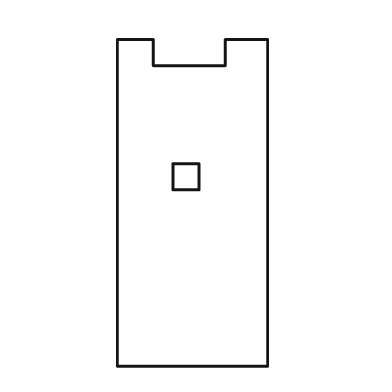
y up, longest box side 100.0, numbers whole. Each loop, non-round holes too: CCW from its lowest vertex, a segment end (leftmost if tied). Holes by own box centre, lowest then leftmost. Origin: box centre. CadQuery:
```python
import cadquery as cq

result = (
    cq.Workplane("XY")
    .moveTo(-23.0, -50.0)
    .lineTo(23.0, -50.0)
    .lineTo(23.0, 50.0)
    .lineTo(10.0, 50.0)
    .lineTo(10.0, 42.0)
    .lineTo(-12.0, 42.0)
    .lineTo(-12.0, 50.0)
    .lineTo(-23.0, 50.0)
    .close()
    .moveTo(-6.0, 4.0)
    .lineTo(2.0, 4.0)
    .lineTo(2.0, 12.0)
    .lineTo(-6.0, 12.0)
    .close()
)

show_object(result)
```